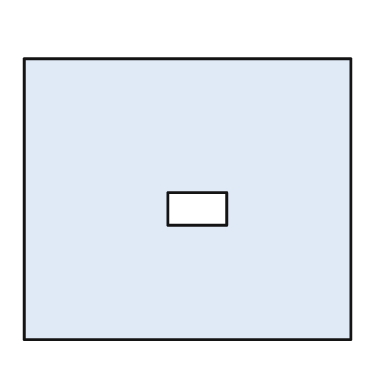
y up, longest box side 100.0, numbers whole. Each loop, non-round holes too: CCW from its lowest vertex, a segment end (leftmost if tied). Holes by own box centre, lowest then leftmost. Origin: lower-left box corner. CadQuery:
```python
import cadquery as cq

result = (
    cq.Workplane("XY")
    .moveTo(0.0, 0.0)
    .lineTo(100.0, 0.0)
    .lineTo(100.0, 86.0)
    .lineTo(0.0, 86.0)
    .close()
    .moveTo(44.0, 35.0)
    .lineTo(62.0, 35.0)
    .lineTo(62.0, 45.0)
    .lineTo(44.0, 45.0)
    .close()
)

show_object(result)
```